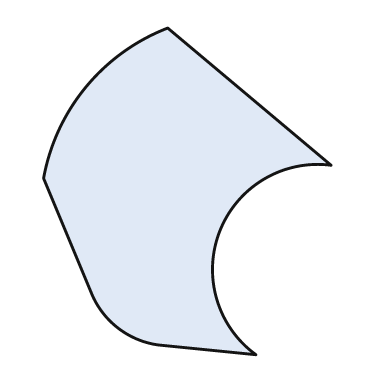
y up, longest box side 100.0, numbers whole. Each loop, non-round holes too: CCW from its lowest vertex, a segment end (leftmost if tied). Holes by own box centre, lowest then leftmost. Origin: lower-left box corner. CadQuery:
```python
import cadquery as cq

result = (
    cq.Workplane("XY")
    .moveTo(65.0, 0.0)
    .threePointArc((54.0, 38.0), (88.0, 58.0))
    .lineTo(38.0, 100.0)
    .threePointArc((13.0, 82.0), (0.0, 54.0))
    .lineTo(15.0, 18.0)
    .threePointArc((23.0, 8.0), (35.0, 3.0))
    .close()
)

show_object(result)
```